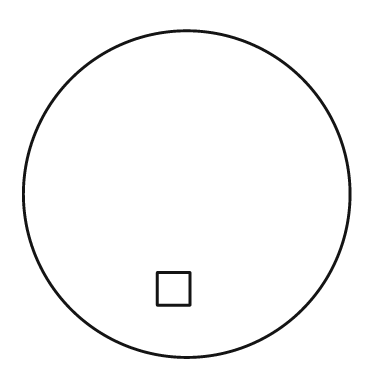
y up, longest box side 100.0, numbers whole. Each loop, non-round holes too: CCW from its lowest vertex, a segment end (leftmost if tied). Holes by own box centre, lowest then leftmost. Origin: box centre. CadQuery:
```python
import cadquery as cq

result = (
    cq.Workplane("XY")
    .moveTo(0.0, 0.0)
    .circle(50.0)
    .moveTo(-9.0, -34.0)
    .lineTo(1.0, -34.0)
    .lineTo(1.0, -24.0)
    .lineTo(-9.0, -24.0)
    .close()
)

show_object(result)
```